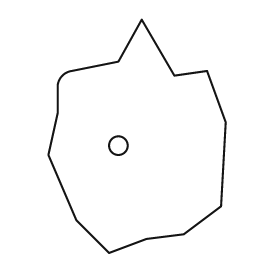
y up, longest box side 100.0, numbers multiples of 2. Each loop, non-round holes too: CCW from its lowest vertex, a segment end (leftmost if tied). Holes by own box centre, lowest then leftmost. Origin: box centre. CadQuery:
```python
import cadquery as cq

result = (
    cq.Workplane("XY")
    .moveTo(-12.0, -50.0)
    .lineTo(4.0, -44.0)
    .lineTo(20.0, -42.0)
    .lineTo(36.0, -30.0)
    .lineTo(38.0, 6.0)
    .lineTo(30.0, 28.0)
    .lineTo(16.0, 26.0)
    .lineTo(2.0, 50.0)
    .lineTo(-8.0, 32.0)
    .lineTo(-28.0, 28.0)
    .threePointArc((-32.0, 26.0), (-34.0, 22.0))
    .lineTo(-34.0, 10.0)
    .lineTo(-38.0, -8.0)
    .lineTo(-26.0, -36.0)
    .close()
    .moveTo(-8.0, -4.0)
    .circle(4.0)
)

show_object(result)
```